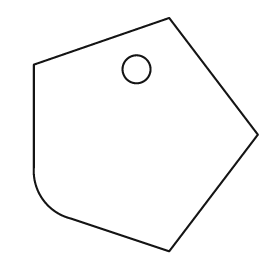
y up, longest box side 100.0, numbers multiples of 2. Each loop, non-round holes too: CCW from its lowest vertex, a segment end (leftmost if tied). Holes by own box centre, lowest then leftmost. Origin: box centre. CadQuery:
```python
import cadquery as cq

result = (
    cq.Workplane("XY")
    .moveTo(10.0, -50.0)
    .lineTo(48.0, 0.0)
    .lineTo(10.0, 50.0)
    .lineTo(-48.0, 30.0)
    .lineTo(-48.0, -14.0)
    .threePointArc((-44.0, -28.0), (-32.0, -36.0))
    .close()
    .moveTo(-4.0, 28.0)
    .circle(6.0)
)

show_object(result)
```